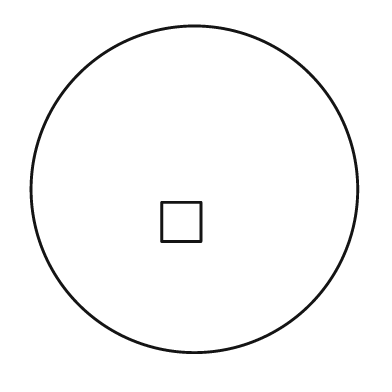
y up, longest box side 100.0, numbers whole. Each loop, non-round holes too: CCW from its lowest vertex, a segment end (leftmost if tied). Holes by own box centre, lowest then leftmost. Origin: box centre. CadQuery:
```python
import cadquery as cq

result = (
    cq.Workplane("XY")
    .moveTo(0.0, 0.0)
    .circle(50.0)
    .moveTo(-10.0, -16.0)
    .lineTo(2.0, -16.0)
    .lineTo(2.0, -4.0)
    .lineTo(-10.0, -4.0)
    .close()
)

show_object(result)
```